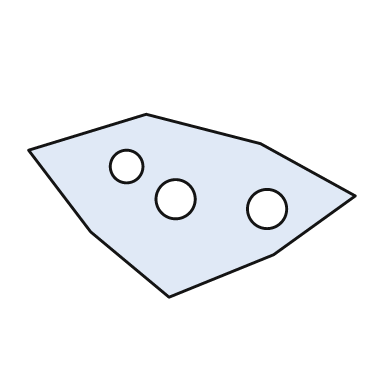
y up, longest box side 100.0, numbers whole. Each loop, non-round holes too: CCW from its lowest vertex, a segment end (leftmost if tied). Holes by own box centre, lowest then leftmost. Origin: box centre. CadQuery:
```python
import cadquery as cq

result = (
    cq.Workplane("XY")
    .moveTo(-7.0, -28.0)
    .lineTo(25.0, -15.0)
    .lineTo(50.0, 3.0)
    .lineTo(21.0, 19.0)
    .lineTo(-14.0, 28.0)
    .lineTo(-50.0, 17.0)
    .lineTo(-31.0, -8.0)
    .close()
    .moveTo(23.0, -1.0)
    .circle(6.0)
    .moveTo(-5.0, 2.0)
    .circle(6.0)
    .moveTo(-20.0, 12.0)
    .circle(5.0)
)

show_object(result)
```